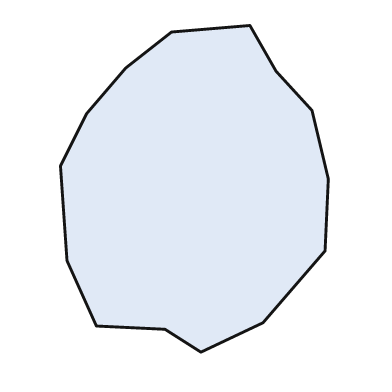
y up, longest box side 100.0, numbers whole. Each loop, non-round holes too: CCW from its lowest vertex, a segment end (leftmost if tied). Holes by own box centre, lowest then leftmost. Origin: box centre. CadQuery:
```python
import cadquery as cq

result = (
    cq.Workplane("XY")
    .moveTo(2.0, -50.0)
    .lineTo(21.0, -41.0)
    .lineTo(40.0, -19.0)
    .lineTo(41.0, 3.0)
    .lineTo(36.0, 24.0)
    .lineTo(25.0, 36.0)
    .lineTo(17.0, 50.0)
    .lineTo(-7.0, 48.0)
    .lineTo(-21.0, 37.0)
    .lineTo(-33.0, 23.0)
    .lineTo(-41.0, 7.0)
    .lineTo(-39.0, -22.0)
    .lineTo(-30.0, -42.0)
    .lineTo(-9.0, -43.0)
    .close()
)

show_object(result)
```